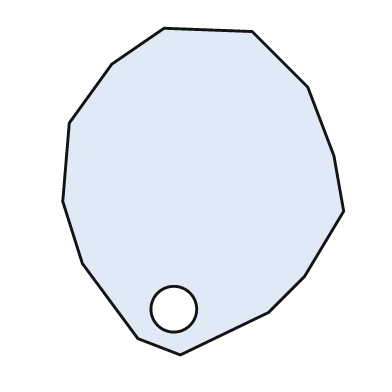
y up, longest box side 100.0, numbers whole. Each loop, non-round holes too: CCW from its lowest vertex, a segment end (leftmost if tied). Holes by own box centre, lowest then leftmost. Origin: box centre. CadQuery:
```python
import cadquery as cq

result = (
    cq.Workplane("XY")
    .moveTo(-7.0, -50.0)
    .lineTo(20.0, -37.0)
    .lineTo(31.0, -26.0)
    .lineTo(43.0, -6.0)
    .lineTo(40.0, 11.0)
    .lineTo(32.0, 32.0)
    .lineTo(15.0, 49.0)
    .lineTo(-12.0, 50.0)
    .lineTo(-28.0, 39.0)
    .lineTo(-41.0, 21.0)
    .lineTo(-43.0, -3.0)
    .lineTo(-37.0, -22.0)
    .lineTo(-20.0, -45.0)
    .close()
    .moveTo(-9.0, -36.0)
    .circle(7.0)
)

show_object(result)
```